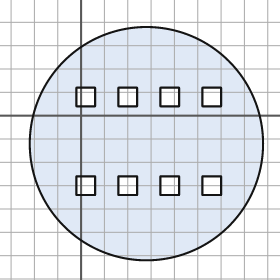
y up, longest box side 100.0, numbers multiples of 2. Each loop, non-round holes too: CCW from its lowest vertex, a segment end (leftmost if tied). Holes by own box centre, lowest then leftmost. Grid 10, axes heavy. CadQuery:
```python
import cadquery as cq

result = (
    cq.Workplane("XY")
    .moveTo(28.0, -12.0)
    .circle(50.0)
    .moveTo(-2.0, -34.0)
    .lineTo(6.0, -34.0)
    .lineTo(6.0, -26.0)
    .lineTo(-2.0, -26.0)
    .close()
    .moveTo(16.0, -34.0)
    .lineTo(24.0, -34.0)
    .lineTo(24.0, -26.0)
    .lineTo(16.0, -26.0)
    .close()
    .moveTo(34.0, -34.0)
    .lineTo(42.0, -34.0)
    .lineTo(42.0, -26.0)
    .lineTo(34.0, -26.0)
    .close()
    .moveTo(52.0, -34.0)
    .lineTo(60.0, -34.0)
    .lineTo(60.0, -26.0)
    .lineTo(52.0, -26.0)
    .close()
    .moveTo(-2.0, 4.0)
    .lineTo(6.0, 4.0)
    .lineTo(6.0, 12.0)
    .lineTo(-2.0, 12.0)
    .close()
    .moveTo(16.0, 4.0)
    .lineTo(24.0, 4.0)
    .lineTo(24.0, 12.0)
    .lineTo(16.0, 12.0)
    .close()
    .moveTo(34.0, 4.0)
    .lineTo(42.0, 4.0)
    .lineTo(42.0, 12.0)
    .lineTo(34.0, 12.0)
    .close()
    .moveTo(52.0, 4.0)
    .lineTo(60.0, 4.0)
    .lineTo(60.0, 12.0)
    .lineTo(52.0, 12.0)
    .close()
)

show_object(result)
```